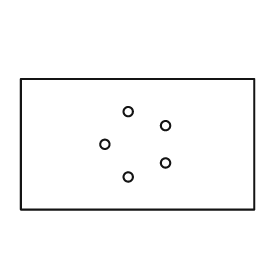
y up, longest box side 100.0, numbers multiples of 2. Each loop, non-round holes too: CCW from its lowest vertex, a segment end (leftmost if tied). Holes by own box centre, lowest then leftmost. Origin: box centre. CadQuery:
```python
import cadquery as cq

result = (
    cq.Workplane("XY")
    .moveTo(-50.0, -28.0)
    .lineTo(50.0, -28.0)
    .lineTo(50.0, 28.0)
    .lineTo(-50.0, 28.0)
    .close()
    .moveTo(-4.0, -14.0)
    .circle(2.0)
    .moveTo(12.0, -8.0)
    .circle(2.0)
    .moveTo(-14.0, 0.0)
    .circle(2.0)
    .moveTo(12.0, 8.0)
    .circle(2.0)
    .moveTo(-4.0, 14.0)
    .circle(2.0)
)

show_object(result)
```